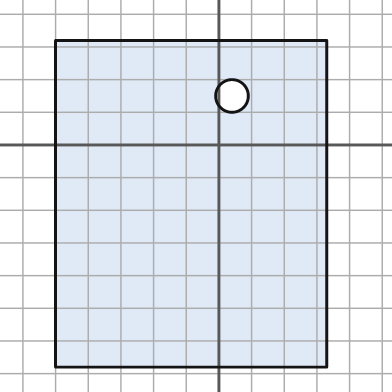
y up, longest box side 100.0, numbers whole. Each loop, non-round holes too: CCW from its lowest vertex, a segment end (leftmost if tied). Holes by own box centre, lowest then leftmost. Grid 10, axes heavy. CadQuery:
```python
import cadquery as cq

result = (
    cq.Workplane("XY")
    .moveTo(-50.0, -68.0)
    .lineTo(33.0, -68.0)
    .lineTo(33.0, 32.0)
    .lineTo(-50.0, 32.0)
    .close()
    .moveTo(4.0, 15.0)
    .circle(5.0)
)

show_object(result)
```